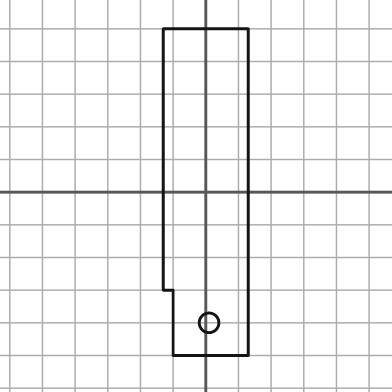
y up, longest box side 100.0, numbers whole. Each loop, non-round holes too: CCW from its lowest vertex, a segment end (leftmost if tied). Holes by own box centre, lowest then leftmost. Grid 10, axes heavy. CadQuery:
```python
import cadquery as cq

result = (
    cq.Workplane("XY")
    .moveTo(-10.0, -50.0)
    .lineTo(13.0, -50.0)
    .lineTo(13.0, 50.0)
    .lineTo(-13.0, 50.0)
    .lineTo(-13.0, -30.0)
    .lineTo(-10.0, -30.0)
    .close()
    .moveTo(1.0, -40.0)
    .circle(3.0)
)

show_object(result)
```